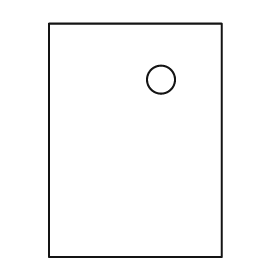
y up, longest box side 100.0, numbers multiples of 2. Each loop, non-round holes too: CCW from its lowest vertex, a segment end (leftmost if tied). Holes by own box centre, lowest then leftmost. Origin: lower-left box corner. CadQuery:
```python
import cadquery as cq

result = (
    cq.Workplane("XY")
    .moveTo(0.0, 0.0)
    .lineTo(74.0, 0.0)
    .lineTo(74.0, 100.0)
    .lineTo(0.0, 100.0)
    .close()
    .moveTo(48.0, 76.0)
    .circle(6.0)
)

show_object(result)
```